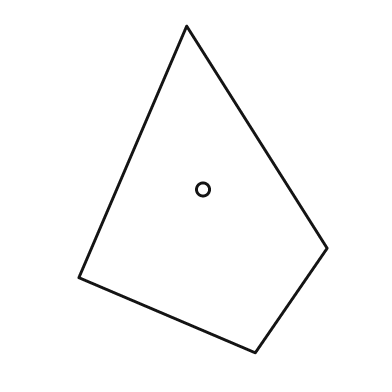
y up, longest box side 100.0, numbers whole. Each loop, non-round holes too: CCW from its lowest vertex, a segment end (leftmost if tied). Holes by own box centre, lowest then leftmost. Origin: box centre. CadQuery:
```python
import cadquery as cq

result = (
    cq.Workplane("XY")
    .moveTo(16.0, -50.0)
    .lineTo(38.0, -18.0)
    .lineTo(-5.0, 50.0)
    .lineTo(-38.0, -27.0)
    .close()
    .moveTo(0.0, 0.0)
    .circle(2.0)
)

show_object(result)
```